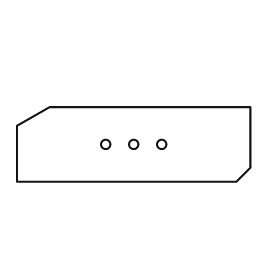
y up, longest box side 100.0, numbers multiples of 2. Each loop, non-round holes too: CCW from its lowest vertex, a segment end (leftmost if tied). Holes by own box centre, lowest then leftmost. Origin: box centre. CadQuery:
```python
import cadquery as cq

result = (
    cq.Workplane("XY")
    .moveTo(-50.0, -16.0)
    .lineTo(44.0, -16.0)
    .lineTo(50.0, -10.0)
    .lineTo(50.0, 16.0)
    .lineTo(-36.0, 16.0)
    .lineTo(-50.0, 8.0)
    .close()
    .moveTo(-12.0, 0.0)
    .circle(2.0)
    .moveTo(0.0, 0.0)
    .circle(2.0)
    .moveTo(12.0, 0.0)
    .circle(2.0)
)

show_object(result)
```